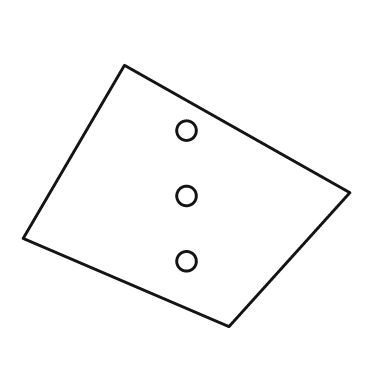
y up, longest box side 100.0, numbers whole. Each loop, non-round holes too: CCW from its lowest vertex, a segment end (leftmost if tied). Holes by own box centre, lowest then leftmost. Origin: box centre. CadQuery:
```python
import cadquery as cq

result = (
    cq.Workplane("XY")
    .moveTo(13.0, -40.0)
    .lineTo(50.0, 1.0)
    .lineTo(-19.0, 40.0)
    .lineTo(-50.0, -13.0)
    .close()
    .moveTo(0.0, -20.0)
    .circle(3.0)
    .moveTo(0.0, 0.0)
    .circle(3.0)
    .moveTo(0.0, 20.0)
    .circle(3.0)
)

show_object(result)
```